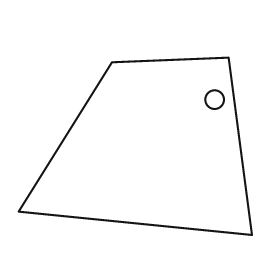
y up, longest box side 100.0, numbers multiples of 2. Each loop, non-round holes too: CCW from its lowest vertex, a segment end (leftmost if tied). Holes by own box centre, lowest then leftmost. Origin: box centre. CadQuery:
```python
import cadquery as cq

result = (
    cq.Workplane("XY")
    .moveTo(50.0, -38.0)
    .lineTo(40.0, 38.0)
    .lineTo(-10.0, 36.0)
    .lineTo(-50.0, -28.0)
    .close()
    .moveTo(34.0, 20.0)
    .circle(4.0)
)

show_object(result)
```